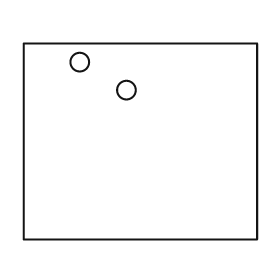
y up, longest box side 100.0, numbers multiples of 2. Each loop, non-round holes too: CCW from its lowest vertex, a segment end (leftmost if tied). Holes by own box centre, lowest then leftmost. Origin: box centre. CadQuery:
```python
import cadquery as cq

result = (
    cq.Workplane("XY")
    .moveTo(-50.0, -42.0)
    .lineTo(50.0, -42.0)
    .lineTo(50.0, 42.0)
    .lineTo(-50.0, 42.0)
    .close()
    .moveTo(-6.0, 22.0)
    .circle(4.0)
    .moveTo(-26.0, 34.0)
    .circle(4.0)
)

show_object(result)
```